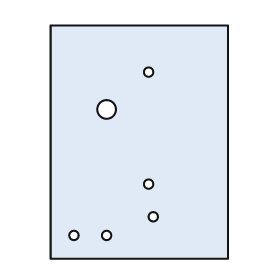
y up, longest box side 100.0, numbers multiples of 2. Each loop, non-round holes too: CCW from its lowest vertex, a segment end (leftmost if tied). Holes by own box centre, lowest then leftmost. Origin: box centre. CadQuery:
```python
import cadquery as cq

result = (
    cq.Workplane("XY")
    .moveTo(-38.0, -50.0)
    .lineTo(38.0, -50.0)
    .lineTo(38.0, 50.0)
    .lineTo(-38.0, 50.0)
    .close()
    .moveTo(-28.0, -40.0)
    .circle(2.0)
    .moveTo(-14.0, -40.0)
    .circle(2.0)
    .moveTo(6.0, -32.0)
    .circle(2.0)
    .moveTo(4.0, -18.0)
    .circle(2.0)
    .moveTo(-14.0, 14.0)
    .circle(4.0)
    .moveTo(4.0, 30.0)
    .circle(2.0)
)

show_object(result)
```